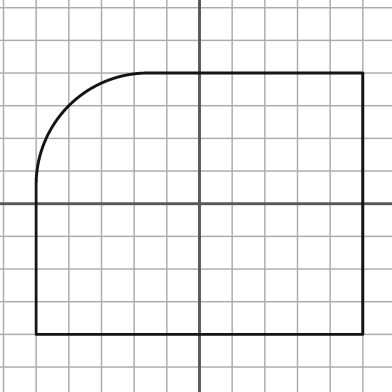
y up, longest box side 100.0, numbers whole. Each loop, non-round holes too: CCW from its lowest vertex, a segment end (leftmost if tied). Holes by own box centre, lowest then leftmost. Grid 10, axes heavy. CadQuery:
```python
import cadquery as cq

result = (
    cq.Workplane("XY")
    .moveTo(-50.0, -40.0)
    .lineTo(50.0, -40.0)
    .lineTo(50.0, 40.0)
    .lineTo(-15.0, 40.0)
    .threePointArc((-40.0, 30.0), (-50.0, 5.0))
    .close()
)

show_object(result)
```